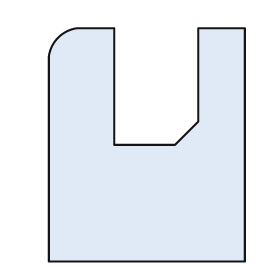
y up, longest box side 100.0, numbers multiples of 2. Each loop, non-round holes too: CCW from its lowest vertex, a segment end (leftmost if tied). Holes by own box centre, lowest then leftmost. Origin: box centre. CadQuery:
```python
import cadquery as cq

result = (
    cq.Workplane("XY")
    .moveTo(-42.0, -50.0)
    .lineTo(42.0, -50.0)
    .lineTo(42.0, 50.0)
    .lineTo(22.0, 50.0)
    .lineTo(22.0, 10.0)
    .lineTo(12.0, 0.0)
    .lineTo(-14.0, 0.0)
    .lineTo(-14.0, 50.0)
    .lineTo(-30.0, 50.0)
    .threePointArc((-38.0, 46.0), (-42.0, 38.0))
    .close()
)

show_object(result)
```